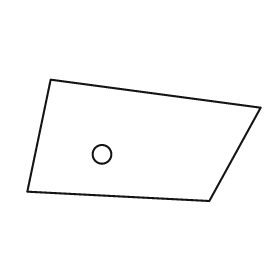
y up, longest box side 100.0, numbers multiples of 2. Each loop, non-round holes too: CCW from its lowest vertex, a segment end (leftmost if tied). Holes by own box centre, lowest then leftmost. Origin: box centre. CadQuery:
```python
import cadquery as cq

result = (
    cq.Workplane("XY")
    .moveTo(28.0, -26.0)
    .lineTo(50.0, 14.0)
    .lineTo(-40.0, 26.0)
    .lineTo(-50.0, -22.0)
    .close()
    .moveTo(-18.0, -6.0)
    .circle(4.0)
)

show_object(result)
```